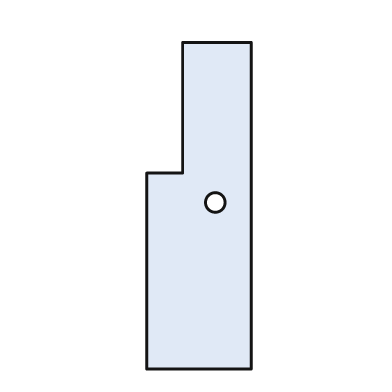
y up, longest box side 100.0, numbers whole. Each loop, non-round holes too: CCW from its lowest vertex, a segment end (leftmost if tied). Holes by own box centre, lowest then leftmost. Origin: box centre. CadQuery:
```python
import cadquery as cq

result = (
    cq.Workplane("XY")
    .moveTo(-16.0, -50.0)
    .lineTo(16.0, -50.0)
    .lineTo(16.0, 50.0)
    .lineTo(-5.0, 50.0)
    .lineTo(-5.0, 10.0)
    .lineTo(-16.0, 10.0)
    .close()
    .moveTo(5.0, 1.0)
    .circle(3.0)
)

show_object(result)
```